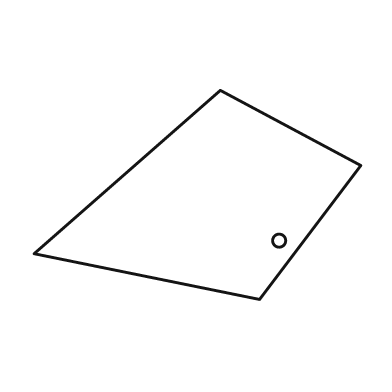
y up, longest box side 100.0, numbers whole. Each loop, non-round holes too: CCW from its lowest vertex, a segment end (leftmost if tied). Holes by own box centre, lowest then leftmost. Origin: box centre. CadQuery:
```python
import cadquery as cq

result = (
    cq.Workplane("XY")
    .moveTo(19.0, -32.0)
    .lineTo(50.0, 9.0)
    .lineTo(7.0, 32.0)
    .lineTo(-50.0, -18.0)
    .close()
    .moveTo(25.0, -14.0)
    .circle(2.0)
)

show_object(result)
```